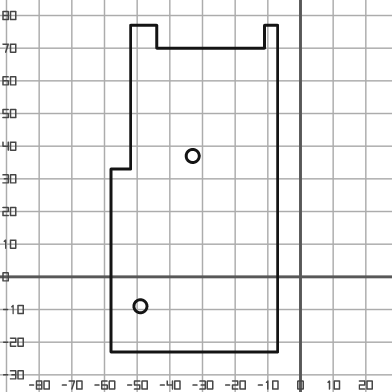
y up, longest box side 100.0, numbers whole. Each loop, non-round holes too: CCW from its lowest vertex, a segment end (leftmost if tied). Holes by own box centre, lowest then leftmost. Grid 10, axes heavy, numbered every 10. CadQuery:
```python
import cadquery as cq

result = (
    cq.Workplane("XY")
    .moveTo(-58.0, -23.0)
    .lineTo(-7.0, -23.0)
    .lineTo(-7.0, 77.0)
    .lineTo(-11.0, 77.0)
    .lineTo(-11.0, 70.0)
    .lineTo(-44.0, 70.0)
    .lineTo(-44.0, 77.0)
    .lineTo(-52.0, 77.0)
    .lineTo(-52.0, 33.0)
    .lineTo(-58.0, 33.0)
    .close()
    .moveTo(-49.0, -9.0)
    .circle(2.0)
    .moveTo(-33.0, 37.0)
    .circle(2.0)
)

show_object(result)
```